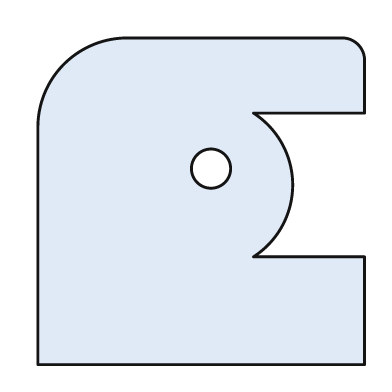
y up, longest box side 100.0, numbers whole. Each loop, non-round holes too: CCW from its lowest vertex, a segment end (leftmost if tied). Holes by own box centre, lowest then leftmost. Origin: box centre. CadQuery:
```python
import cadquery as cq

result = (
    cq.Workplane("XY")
    .moveTo(-50.0, -50.0)
    .lineTo(50.0, -50.0)
    .lineTo(50.0, -17.0)
    .lineTo(16.0, -17.0)
    .threePointArc((28.0, 5.0), (16.0, 27.0))
    .lineTo(50.0, 27.0)
    .lineTo(50.0, 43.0)
    .threePointArc((48.0, 48.0), (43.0, 50.0))
    .lineTo(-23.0, 50.0)
    .threePointArc((-42.0, 42.0), (-50.0, 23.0))
    .close()
    .moveTo(3.0, 10.0)
    .circle(6.0)
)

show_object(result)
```